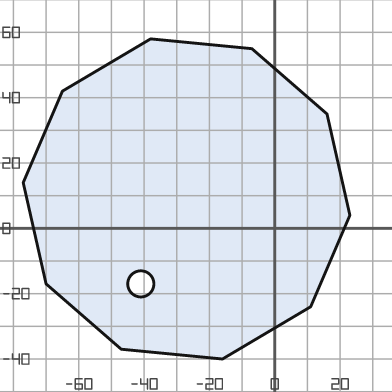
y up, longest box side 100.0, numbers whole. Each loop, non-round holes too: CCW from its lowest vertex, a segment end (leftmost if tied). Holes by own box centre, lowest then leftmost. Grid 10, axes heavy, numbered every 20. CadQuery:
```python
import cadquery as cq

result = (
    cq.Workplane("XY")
    .moveTo(-16.0, -40.0)
    .lineTo(11.0, -24.0)
    .lineTo(23.0, 4.0)
    .lineTo(16.0, 35.0)
    .lineTo(-7.0, 55.0)
    .lineTo(-38.0, 58.0)
    .lineTo(-65.0, 42.0)
    .lineTo(-77.0, 14.0)
    .lineTo(-70.0, -17.0)
    .lineTo(-47.0, -37.0)
    .close()
    .moveTo(-41.0, -17.0)
    .circle(4.0)
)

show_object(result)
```